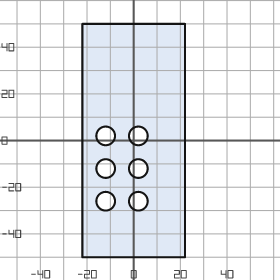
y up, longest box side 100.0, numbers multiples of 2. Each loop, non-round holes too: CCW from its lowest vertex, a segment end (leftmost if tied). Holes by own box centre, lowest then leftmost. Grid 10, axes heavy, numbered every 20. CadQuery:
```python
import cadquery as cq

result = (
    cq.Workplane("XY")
    .moveTo(-22.0, -50.0)
    .lineTo(22.0, -50.0)
    .lineTo(22.0, 50.0)
    .lineTo(-22.0, 50.0)
    .close()
    .moveTo(-12.0, -26.0)
    .circle(4.0)
    .moveTo(2.0, -26.0)
    .circle(4.0)
    .moveTo(-12.0, -12.0)
    .circle(4.0)
    .moveTo(2.0, -12.0)
    .circle(4.0)
    .moveTo(-12.0, 2.0)
    .circle(4.0)
    .moveTo(2.0, 2.0)
    .circle(4.0)
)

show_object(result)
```